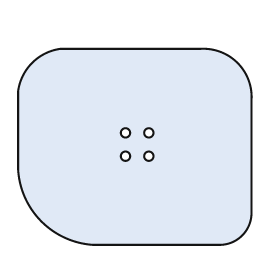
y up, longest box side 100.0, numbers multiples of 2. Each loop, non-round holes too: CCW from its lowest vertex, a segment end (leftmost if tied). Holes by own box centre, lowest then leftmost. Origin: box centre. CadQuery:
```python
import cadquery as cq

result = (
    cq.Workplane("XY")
    .moveTo(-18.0, -42.0)
    .lineTo(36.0, -42.0)
    .threePointArc((46.0, -38.0), (50.0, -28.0))
    .lineTo(50.0, 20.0)
    .threePointArc((44.0, 36.0), (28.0, 42.0))
    .lineTo(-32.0, 42.0)
    .threePointArc((-44.0, 36.0), (-50.0, 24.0))
    .lineTo(-50.0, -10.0)
    .threePointArc((-40.0, -32.0), (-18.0, -42.0))
    .close()
    .moveTo(-4.0, -4.0)
    .circle(2.0)
    .moveTo(6.0, -4.0)
    .circle(2.0)
    .moveTo(-4.0, 6.0)
    .circle(2.0)
    .moveTo(6.0, 6.0)
    .circle(2.0)
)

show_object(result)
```